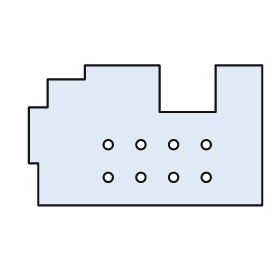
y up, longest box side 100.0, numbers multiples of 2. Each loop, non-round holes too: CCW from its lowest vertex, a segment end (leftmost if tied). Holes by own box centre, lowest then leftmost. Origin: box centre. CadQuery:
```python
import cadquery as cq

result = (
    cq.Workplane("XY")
    .moveTo(-46.0, -30.0)
    .lineTo(50.0, -30.0)
    .lineTo(50.0, 30.0)
    .lineTo(30.0, 30.0)
    .lineTo(30.0, 10.0)
    .lineTo(6.0, 10.0)
    .lineTo(6.0, 30.0)
    .lineTo(-26.0, 30.0)
    .lineTo(-26.0, 24.0)
    .lineTo(-42.0, 24.0)
    .lineTo(-42.0, 12.0)
    .lineTo(-50.0, 12.0)
    .lineTo(-50.0, -12.0)
    .lineTo(-46.0, -12.0)
    .close()
    .moveTo(-16.0, -18.0)
    .circle(2.0)
    .moveTo(-2.0, -18.0)
    .circle(2.0)
    .moveTo(12.0, -18.0)
    .circle(2.0)
    .moveTo(26.0, -18.0)
    .circle(2.0)
    .moveTo(-16.0, -4.0)
    .circle(2.0)
    .moveTo(-2.0, -4.0)
    .circle(2.0)
    .moveTo(12.0, -4.0)
    .circle(2.0)
    .moveTo(26.0, -4.0)
    .circle(2.0)
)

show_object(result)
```